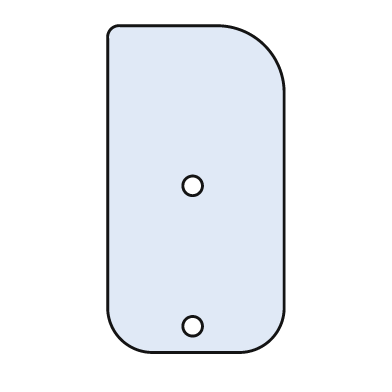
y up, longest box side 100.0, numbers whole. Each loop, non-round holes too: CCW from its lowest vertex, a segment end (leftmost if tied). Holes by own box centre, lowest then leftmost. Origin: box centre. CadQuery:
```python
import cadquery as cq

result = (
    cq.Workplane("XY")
    .moveTo(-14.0, -50.0)
    .lineTo(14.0, -50.0)
    .threePointArc((23.0, -46.0), (27.0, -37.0))
    .lineTo(27.0, 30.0)
    .threePointArc((21.0, 44.0), (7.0, 50.0))
    .lineTo(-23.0, 50.0)
    .threePointArc((-26.0, 49.0), (-27.0, 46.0))
    .lineTo(-27.0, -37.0)
    .threePointArc((-23.0, -46.0), (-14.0, -50.0))
    .close()
    .moveTo(-1.0, -42.0)
    .circle(3.0)
    .moveTo(-1.0, 1.0)
    .circle(3.0)
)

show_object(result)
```